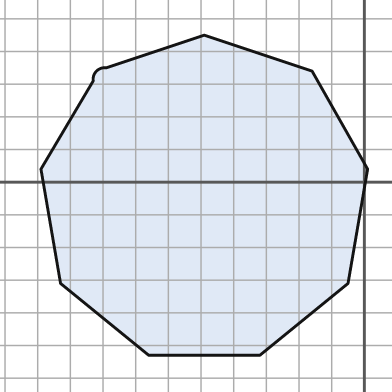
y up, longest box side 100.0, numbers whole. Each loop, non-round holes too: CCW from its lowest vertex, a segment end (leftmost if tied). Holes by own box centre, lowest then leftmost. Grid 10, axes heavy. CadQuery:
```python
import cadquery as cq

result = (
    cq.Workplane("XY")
    .moveTo(-66.0, -53.0)
    .lineTo(-32.0, -53.0)
    .lineTo(-5.0, -31.0)
    .lineTo(1.0, 4.0)
    .lineTo(-16.0, 34.0)
    .lineTo(-49.0, 45.0)
    .lineTo(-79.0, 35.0)
    .threePointArc((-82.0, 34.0), (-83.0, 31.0))
    .lineTo(-99.0, 4.0)
    .lineTo(-93.0, -31.0)
    .close()
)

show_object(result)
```